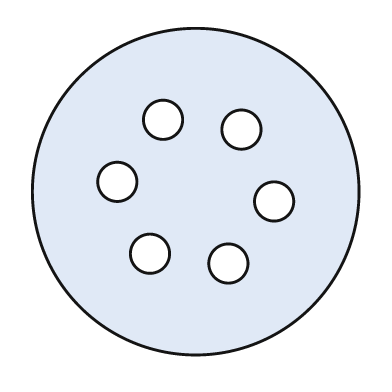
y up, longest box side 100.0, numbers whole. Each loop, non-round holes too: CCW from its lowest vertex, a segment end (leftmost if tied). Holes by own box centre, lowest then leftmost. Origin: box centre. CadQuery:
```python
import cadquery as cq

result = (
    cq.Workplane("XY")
    .moveTo(0.0, 0.0)
    .circle(50.0)
    .moveTo(10.0, -22.0)
    .circle(6.0)
    .moveTo(-14.0, -19.0)
    .circle(6.0)
    .moveTo(24.0, -3.0)
    .circle(6.0)
    .moveTo(-24.0, 3.0)
    .circle(6.0)
    .moveTo(14.0, 19.0)
    .circle(6.0)
    .moveTo(-10.0, 22.0)
    .circle(6.0)
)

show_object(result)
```